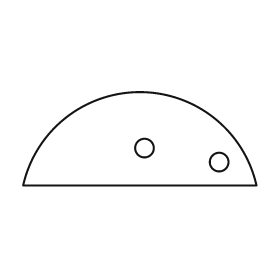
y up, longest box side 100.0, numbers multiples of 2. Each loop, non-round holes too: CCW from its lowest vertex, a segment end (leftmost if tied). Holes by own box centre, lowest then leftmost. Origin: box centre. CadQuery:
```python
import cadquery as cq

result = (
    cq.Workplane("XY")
    .moveTo(-50.0, -20.0)
    .lineTo(50.0, -20.0)
    .threePointArc((0.0, 20.0), (-50.0, -20.0))
    .close()
    .moveTo(34.0, -10.0)
    .circle(4.0)
    .moveTo(2.0, -4.0)
    .circle(4.0)
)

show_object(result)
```